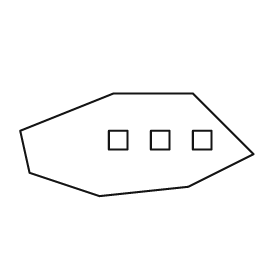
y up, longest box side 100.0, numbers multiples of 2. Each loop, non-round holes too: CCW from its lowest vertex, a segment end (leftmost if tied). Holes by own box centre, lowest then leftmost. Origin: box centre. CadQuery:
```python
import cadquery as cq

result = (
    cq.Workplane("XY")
    .moveTo(-16.0, -22.0)
    .lineTo(22.0, -18.0)
    .lineTo(50.0, -4.0)
    .lineTo(24.0, 22.0)
    .lineTo(-10.0, 22.0)
    .lineTo(-50.0, 6.0)
    .lineTo(-46.0, -12.0)
    .close()
    .moveTo(-12.0, -2.0)
    .lineTo(-4.0, -2.0)
    .lineTo(-4.0, 6.0)
    .lineTo(-12.0, 6.0)
    .close()
    .moveTo(6.0, -2.0)
    .lineTo(14.0, -2.0)
    .lineTo(14.0, 6.0)
    .lineTo(6.0, 6.0)
    .close()
    .moveTo(24.0, -2.0)
    .lineTo(32.0, -2.0)
    .lineTo(32.0, 6.0)
    .lineTo(24.0, 6.0)
    .close()
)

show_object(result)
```